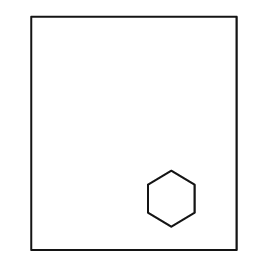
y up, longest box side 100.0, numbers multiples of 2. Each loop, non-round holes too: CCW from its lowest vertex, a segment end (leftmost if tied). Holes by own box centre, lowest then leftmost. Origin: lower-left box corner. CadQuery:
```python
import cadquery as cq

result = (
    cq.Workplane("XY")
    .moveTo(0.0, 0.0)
    .lineTo(88.0, 0.0)
    .lineTo(88.0, 100.0)
    .lineTo(0.0, 100.0)
    .close()
    .moveTo(60.0, 10.0)
    .lineTo(70.0, 16.0)
    .lineTo(70.0, 28.0)
    .lineTo(60.0, 34.0)
    .lineTo(50.0, 28.0)
    .lineTo(50.0, 16.0)
    .close()
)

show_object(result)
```